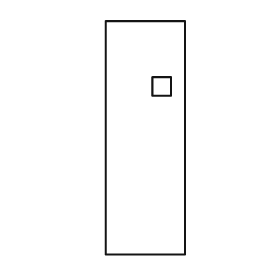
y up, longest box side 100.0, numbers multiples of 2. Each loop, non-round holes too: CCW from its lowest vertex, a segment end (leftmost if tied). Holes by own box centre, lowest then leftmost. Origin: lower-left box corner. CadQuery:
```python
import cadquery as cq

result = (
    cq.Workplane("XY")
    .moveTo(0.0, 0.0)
    .lineTo(34.0, 0.0)
    .lineTo(34.0, 100.0)
    .lineTo(0.0, 100.0)
    .close()
    .moveTo(20.0, 68.0)
    .lineTo(28.0, 68.0)
    .lineTo(28.0, 76.0)
    .lineTo(20.0, 76.0)
    .close()
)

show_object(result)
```